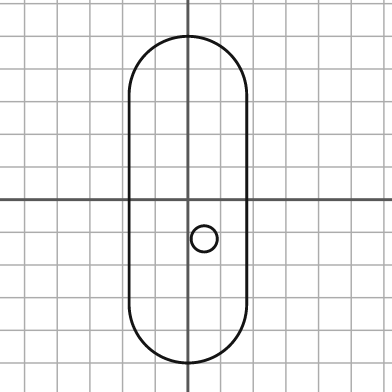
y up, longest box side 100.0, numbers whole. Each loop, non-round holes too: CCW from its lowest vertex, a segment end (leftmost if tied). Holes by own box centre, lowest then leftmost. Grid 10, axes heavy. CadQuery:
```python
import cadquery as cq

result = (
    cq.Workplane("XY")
    .moveTo(-18.0, -32.0)
    .threePointArc((0.0, -50.0), (18.0, -32.0))
    .lineTo(18.0, 32.0)
    .threePointArc((0.0, 50.0), (-18.0, 32.0))
    .close()
    .moveTo(5.0, -12.0)
    .circle(4.0)
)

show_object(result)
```